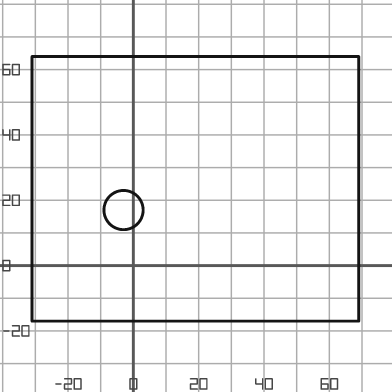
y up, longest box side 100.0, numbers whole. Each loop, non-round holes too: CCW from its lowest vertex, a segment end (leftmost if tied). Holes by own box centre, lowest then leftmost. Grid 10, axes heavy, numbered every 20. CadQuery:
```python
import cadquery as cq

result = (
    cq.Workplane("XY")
    .moveTo(-31.0, -17.0)
    .lineTo(69.0, -17.0)
    .lineTo(69.0, 64.0)
    .lineTo(-31.0, 64.0)
    .close()
    .moveTo(-3.0, 17.0)
    .circle(6.0)
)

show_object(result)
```